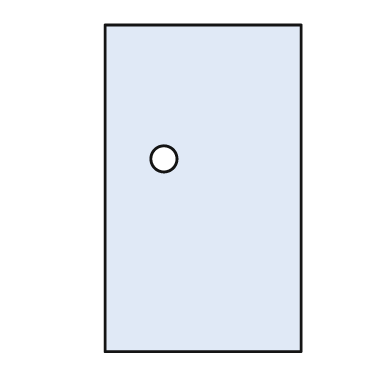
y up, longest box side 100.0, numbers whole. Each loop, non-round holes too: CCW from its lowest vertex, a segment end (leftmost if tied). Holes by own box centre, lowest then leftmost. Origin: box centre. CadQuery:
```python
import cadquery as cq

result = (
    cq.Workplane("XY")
    .moveTo(-30.0, -50.0)
    .lineTo(30.0, -50.0)
    .lineTo(30.0, 50.0)
    .lineTo(-30.0, 50.0)
    .close()
    .moveTo(-12.0, 9.0)
    .circle(4.0)
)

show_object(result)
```